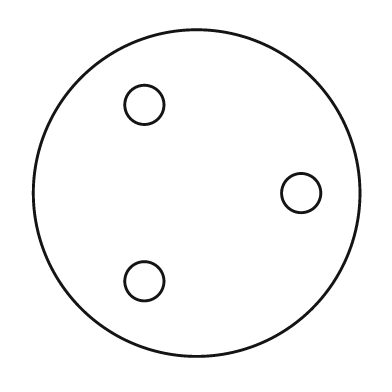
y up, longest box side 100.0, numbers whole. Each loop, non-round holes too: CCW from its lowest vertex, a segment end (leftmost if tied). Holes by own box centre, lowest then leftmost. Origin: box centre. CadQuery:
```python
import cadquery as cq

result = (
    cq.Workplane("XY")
    .moveTo(0.0, 0.0)
    .circle(50.0)
    .moveTo(-16.0, -27.0)
    .circle(6.0)
    .moveTo(32.0, 0.0)
    .circle(6.0)
    .moveTo(-16.0, 27.0)
    .circle(6.0)
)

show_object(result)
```